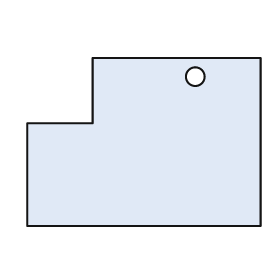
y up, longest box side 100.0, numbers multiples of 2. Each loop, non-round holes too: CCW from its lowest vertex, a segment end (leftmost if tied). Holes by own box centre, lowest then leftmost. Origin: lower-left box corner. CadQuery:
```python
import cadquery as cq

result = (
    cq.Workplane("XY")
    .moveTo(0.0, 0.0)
    .lineTo(100.0, 0.0)
    .lineTo(100.0, 72.0)
    .lineTo(28.0, 72.0)
    .lineTo(28.0, 44.0)
    .lineTo(0.0, 44.0)
    .close()
    .moveTo(72.0, 64.0)
    .circle(4.0)
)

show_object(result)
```